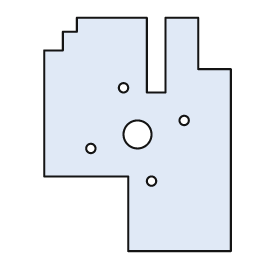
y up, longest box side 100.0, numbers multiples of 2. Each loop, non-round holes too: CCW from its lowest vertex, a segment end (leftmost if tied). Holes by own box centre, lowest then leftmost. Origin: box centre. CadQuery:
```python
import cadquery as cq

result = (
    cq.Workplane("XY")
    .moveTo(-4.0, -50.0)
    .lineTo(40.0, -50.0)
    .lineTo(40.0, 28.0)
    .lineTo(26.0, 28.0)
    .lineTo(26.0, 50.0)
    .lineTo(12.0, 50.0)
    .lineTo(12.0, 18.0)
    .lineTo(4.0, 18.0)
    .lineTo(4.0, 50.0)
    .lineTo(-26.0, 50.0)
    .lineTo(-26.0, 44.0)
    .lineTo(-32.0, 44.0)
    .lineTo(-32.0, 36.0)
    .lineTo(-40.0, 36.0)
    .lineTo(-40.0, -18.0)
    .lineTo(-4.0, -18.0)
    .close()
    .moveTo(6.0, -20.0)
    .circle(2.0)
    .moveTo(-20.0, -6.0)
    .circle(2.0)
    .moveTo(0.0, 0.0)
    .circle(6.0)
    .moveTo(20.0, 6.0)
    .circle(2.0)
    .moveTo(-6.0, 20.0)
    .circle(2.0)
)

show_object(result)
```